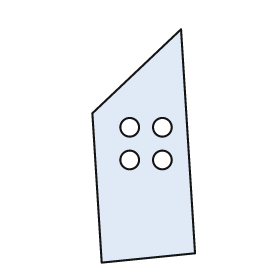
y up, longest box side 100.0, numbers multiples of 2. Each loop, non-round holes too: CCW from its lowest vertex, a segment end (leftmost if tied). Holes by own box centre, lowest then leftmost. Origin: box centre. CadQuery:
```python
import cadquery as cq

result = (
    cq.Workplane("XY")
    .moveTo(-18.0, -50.0)
    .lineTo(22.0, -46.0)
    .lineTo(16.0, 50.0)
    .lineTo(-22.0, 14.0)
    .close()
    .moveTo(-6.0, -6.0)
    .circle(4.0)
    .moveTo(8.0, -6.0)
    .circle(4.0)
    .moveTo(-6.0, 8.0)
    .circle(4.0)
    .moveTo(8.0, 8.0)
    .circle(4.0)
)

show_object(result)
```